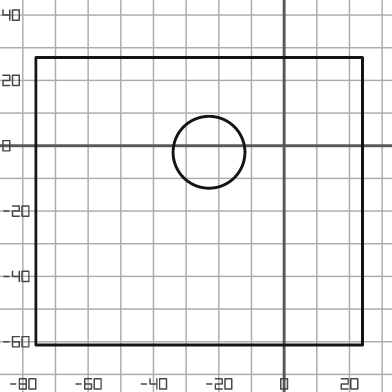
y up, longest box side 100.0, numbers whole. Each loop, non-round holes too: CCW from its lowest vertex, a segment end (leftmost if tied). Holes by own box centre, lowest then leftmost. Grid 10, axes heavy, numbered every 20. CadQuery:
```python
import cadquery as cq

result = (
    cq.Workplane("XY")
    .moveTo(-76.0, -61.0)
    .lineTo(24.0, -61.0)
    .lineTo(24.0, 27.0)
    .lineTo(-76.0, 27.0)
    .close()
    .moveTo(-23.0, -2.0)
    .circle(11.0)
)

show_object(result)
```